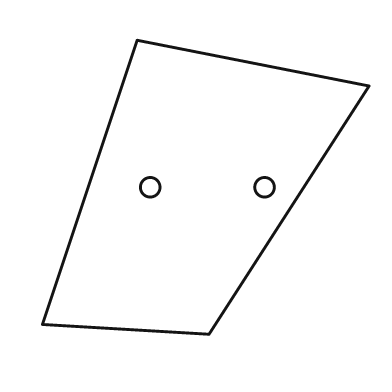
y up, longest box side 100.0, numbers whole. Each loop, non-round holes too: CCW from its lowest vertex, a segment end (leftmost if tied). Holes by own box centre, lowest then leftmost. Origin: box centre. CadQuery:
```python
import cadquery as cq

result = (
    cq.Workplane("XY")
    .moveTo(1.0, -45.0)
    .lineTo(50.0, 31.0)
    .lineTo(-21.0, 45.0)
    .lineTo(-50.0, -42.0)
    .close()
    .moveTo(-17.0, 0.0)
    .circle(3.0)
    .moveTo(18.0, 0.0)
    .circle(3.0)
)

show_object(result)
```